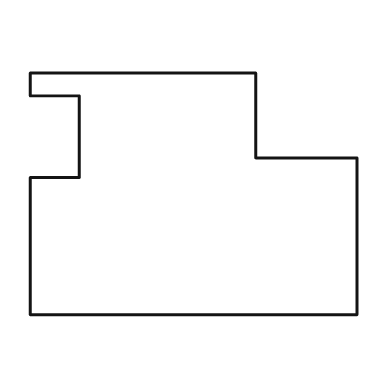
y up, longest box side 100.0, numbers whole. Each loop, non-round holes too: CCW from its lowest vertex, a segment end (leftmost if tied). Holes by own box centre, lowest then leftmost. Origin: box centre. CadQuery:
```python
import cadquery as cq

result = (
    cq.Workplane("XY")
    .moveTo(-50.0, -37.0)
    .lineTo(50.0, -37.0)
    .lineTo(50.0, 11.0)
    .lineTo(19.0, 11.0)
    .lineTo(19.0, 37.0)
    .lineTo(-50.0, 37.0)
    .lineTo(-50.0, 30.0)
    .lineTo(-35.0, 30.0)
    .lineTo(-35.0, 5.0)
    .lineTo(-50.0, 5.0)
    .close()
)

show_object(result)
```